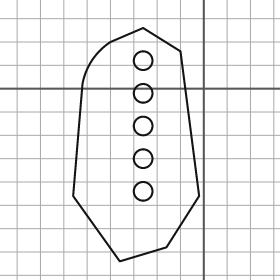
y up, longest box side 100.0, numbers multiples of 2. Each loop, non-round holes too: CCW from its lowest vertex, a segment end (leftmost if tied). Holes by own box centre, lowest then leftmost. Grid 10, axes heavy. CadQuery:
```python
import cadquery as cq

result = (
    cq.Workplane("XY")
    .moveTo(-36.0, -74.0)
    .lineTo(-16.0, -68.0)
    .lineTo(-2.0, -46.0)
    .lineTo(-10.0, 16.0)
    .lineTo(-26.0, 26.0)
    .lineTo(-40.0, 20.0)
    .threePointArc((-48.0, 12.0), (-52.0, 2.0))
    .lineTo(-56.0, -46.0)
    .close()
    .moveTo(-26.0, -44.0)
    .circle(4.0)
    .moveTo(-26.0, -30.0)
    .circle(4.0)
    .moveTo(-26.0, -16.0)
    .circle(4.0)
    .moveTo(-26.0, -2.0)
    .circle(4.0)
    .moveTo(-26.0, 12.0)
    .circle(4.0)
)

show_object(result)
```